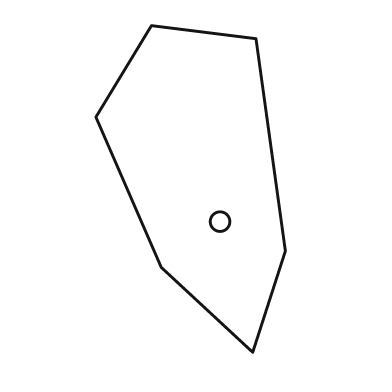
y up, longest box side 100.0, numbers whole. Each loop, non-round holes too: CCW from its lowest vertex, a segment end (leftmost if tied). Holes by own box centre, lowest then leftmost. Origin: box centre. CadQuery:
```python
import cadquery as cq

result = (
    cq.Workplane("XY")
    .moveTo(19.0, -50.0)
    .lineTo(29.0, -19.0)
    .lineTo(20.0, 46.0)
    .lineTo(-12.0, 50.0)
    .lineTo(-29.0, 22.0)
    .lineTo(-9.0, -24.0)
    .close()
    .moveTo(9.0, -10.0)
    .circle(3.0)
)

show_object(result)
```